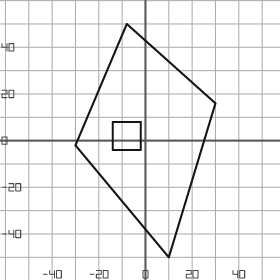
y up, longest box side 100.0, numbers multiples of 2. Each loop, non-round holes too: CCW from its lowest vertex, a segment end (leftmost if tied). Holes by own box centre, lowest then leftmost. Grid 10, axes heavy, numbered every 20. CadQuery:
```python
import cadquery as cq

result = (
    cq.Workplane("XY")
    .moveTo(10.0, -50.0)
    .lineTo(30.0, 16.0)
    .lineTo(-8.0, 50.0)
    .lineTo(-30.0, -2.0)
    .close()
    .moveTo(-14.0, -4.0)
    .lineTo(-2.0, -4.0)
    .lineTo(-2.0, 8.0)
    .lineTo(-14.0, 8.0)
    .close()
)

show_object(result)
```